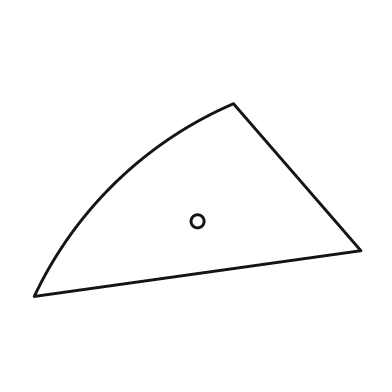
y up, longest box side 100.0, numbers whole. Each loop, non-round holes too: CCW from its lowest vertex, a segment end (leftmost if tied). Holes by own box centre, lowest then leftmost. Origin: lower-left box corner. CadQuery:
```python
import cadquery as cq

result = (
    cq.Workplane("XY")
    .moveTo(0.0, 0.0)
    .lineTo(100.0, 14.0)
    .lineTo(61.0, 59.0)
    .threePointArc((25.0, 35.0), (0.0, 0.0))
    .close()
    .moveTo(50.0, 23.0)
    .circle(2.0)
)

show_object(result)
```